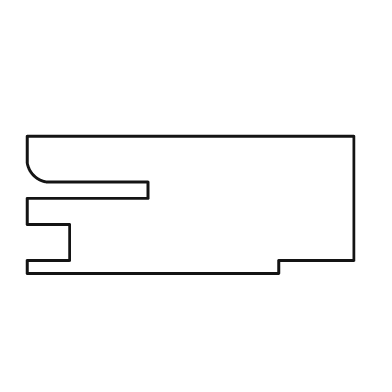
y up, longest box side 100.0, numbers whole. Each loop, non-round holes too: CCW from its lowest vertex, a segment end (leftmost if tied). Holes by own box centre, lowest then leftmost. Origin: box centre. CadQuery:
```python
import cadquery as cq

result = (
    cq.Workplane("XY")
    .moveTo(-50.0, -21.0)
    .lineTo(27.0, -21.0)
    .lineTo(27.0, -17.0)
    .lineTo(50.0, -17.0)
    .lineTo(50.0, 21.0)
    .lineTo(-50.0, 21.0)
    .lineTo(-50.0, 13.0)
    .threePointArc((-48.0, 9.0), (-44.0, 7.0))
    .lineTo(-13.0, 7.0)
    .lineTo(-13.0, 2.0)
    .lineTo(-50.0, 2.0)
    .lineTo(-50.0, -6.0)
    .lineTo(-37.0, -6.0)
    .lineTo(-37.0, -17.0)
    .lineTo(-50.0, -17.0)
    .close()
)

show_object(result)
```